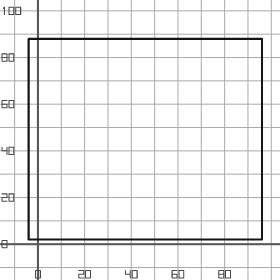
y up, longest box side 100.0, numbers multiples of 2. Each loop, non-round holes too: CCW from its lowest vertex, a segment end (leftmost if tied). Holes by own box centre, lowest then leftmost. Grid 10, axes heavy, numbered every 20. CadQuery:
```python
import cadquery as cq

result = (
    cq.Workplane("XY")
    .moveTo(-4.0, 2.0)
    .lineTo(96.0, 2.0)
    .lineTo(96.0, 88.0)
    .lineTo(-4.0, 88.0)
    .close()
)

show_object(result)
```